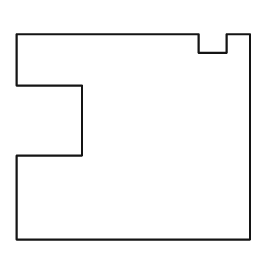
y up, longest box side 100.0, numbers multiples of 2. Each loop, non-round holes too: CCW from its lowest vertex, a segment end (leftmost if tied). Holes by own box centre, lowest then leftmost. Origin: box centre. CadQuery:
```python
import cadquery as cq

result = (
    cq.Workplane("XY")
    .moveTo(-50.0, -44.0)
    .lineTo(50.0, -44.0)
    .lineTo(50.0, 44.0)
    .lineTo(40.0, 44.0)
    .lineTo(40.0, 36.0)
    .lineTo(28.0, 36.0)
    .lineTo(28.0, 44.0)
    .lineTo(-50.0, 44.0)
    .lineTo(-50.0, 22.0)
    .lineTo(-22.0, 22.0)
    .lineTo(-22.0, -8.0)
    .lineTo(-50.0, -8.0)
    .close()
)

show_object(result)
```